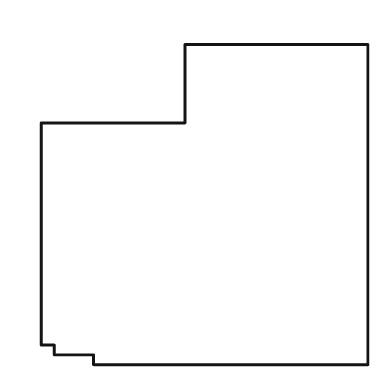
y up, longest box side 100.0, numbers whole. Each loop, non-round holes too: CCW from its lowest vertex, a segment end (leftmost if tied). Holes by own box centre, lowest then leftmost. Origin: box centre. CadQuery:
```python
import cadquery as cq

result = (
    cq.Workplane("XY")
    .moveTo(-34.0, -49.0)
    .lineTo(50.0, -49.0)
    .lineTo(50.0, 49.0)
    .lineTo(-6.0, 49.0)
    .lineTo(-6.0, 25.0)
    .lineTo(-50.0, 25.0)
    .lineTo(-50.0, -43.0)
    .lineTo(-46.0, -43.0)
    .lineTo(-46.0, -46.0)
    .lineTo(-34.0, -46.0)
    .close()
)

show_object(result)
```